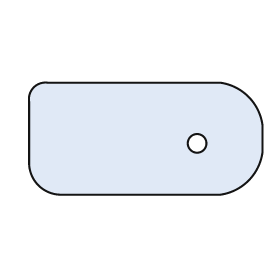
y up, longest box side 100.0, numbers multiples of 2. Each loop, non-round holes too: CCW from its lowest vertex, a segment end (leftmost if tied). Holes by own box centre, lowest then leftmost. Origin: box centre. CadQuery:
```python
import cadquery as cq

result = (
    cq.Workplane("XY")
    .moveTo(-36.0, -24.0)
    .lineTo(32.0, -24.0)
    .threePointArc((44.0, -18.0), (50.0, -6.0))
    .lineTo(50.0, 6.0)
    .threePointArc((44.0, 18.0), (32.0, 24.0))
    .lineTo(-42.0, 24.0)
    .threePointArc((-48.0, 22.0), (-50.0, 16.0))
    .lineTo(-50.0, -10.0)
    .threePointArc((-46.0, -20.0), (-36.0, -24.0))
    .close()
    .moveTo(22.0, -2.0)
    .circle(4.0)
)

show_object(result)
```